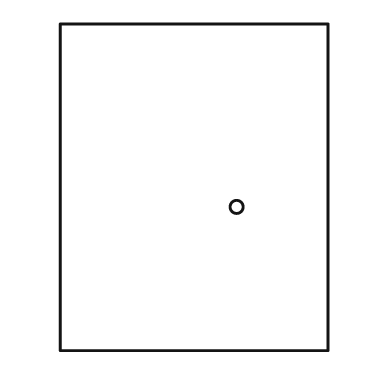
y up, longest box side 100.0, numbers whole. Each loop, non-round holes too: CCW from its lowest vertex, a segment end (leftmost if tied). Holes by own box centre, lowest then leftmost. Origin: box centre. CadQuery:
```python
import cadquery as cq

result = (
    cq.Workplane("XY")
    .moveTo(-41.0, -50.0)
    .lineTo(41.0, -50.0)
    .lineTo(41.0, 50.0)
    .lineTo(-41.0, 50.0)
    .close()
    .moveTo(13.0, -6.0)
    .circle(2.0)
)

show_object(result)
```